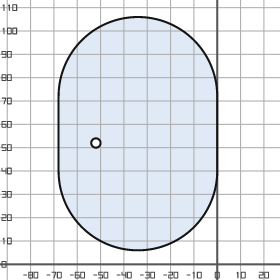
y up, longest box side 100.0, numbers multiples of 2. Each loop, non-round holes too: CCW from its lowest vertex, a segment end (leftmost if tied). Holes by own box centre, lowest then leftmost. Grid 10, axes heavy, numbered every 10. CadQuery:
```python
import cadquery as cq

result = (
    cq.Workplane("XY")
    .moveTo(-68.0, 40.0)
    .threePointArc((-34.0, 6.0), (0.0, 40.0))
    .lineTo(0.0, 72.0)
    .threePointArc((-34.0, 106.0), (-68.0, 72.0))
    .close()
    .moveTo(-52.0, 52.0)
    .circle(2.0)
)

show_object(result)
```